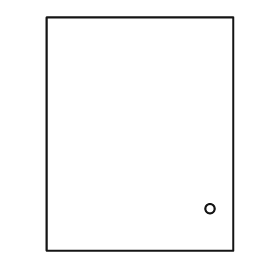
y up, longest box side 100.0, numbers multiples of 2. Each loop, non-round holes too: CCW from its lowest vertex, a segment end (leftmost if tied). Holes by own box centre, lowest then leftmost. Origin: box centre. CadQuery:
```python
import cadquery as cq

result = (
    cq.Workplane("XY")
    .moveTo(-40.0, -50.0)
    .lineTo(40.0, -50.0)
    .lineTo(40.0, 50.0)
    .lineTo(-40.0, 50.0)
    .close()
    .moveTo(30.0, -32.0)
    .circle(2.0)
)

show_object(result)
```